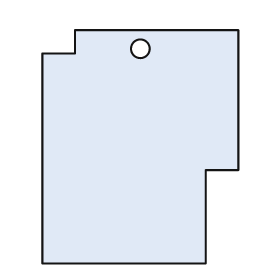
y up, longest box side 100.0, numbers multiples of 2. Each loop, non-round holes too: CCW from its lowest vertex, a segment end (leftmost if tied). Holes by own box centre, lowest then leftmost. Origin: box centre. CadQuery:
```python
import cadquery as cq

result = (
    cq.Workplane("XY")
    .moveTo(-42.0, -50.0)
    .lineTo(28.0, -50.0)
    .lineTo(28.0, -10.0)
    .lineTo(42.0, -10.0)
    .lineTo(42.0, 50.0)
    .lineTo(-28.0, 50.0)
    .lineTo(-28.0, 40.0)
    .lineTo(-42.0, 40.0)
    .close()
    .moveTo(0.0, 42.0)
    .circle(4.0)
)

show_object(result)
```